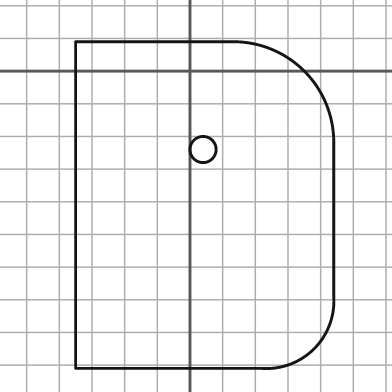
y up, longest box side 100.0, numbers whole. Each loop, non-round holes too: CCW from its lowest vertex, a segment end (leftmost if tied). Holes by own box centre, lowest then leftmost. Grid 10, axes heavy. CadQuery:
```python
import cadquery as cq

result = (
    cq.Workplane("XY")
    .moveTo(-35.0, -91.0)
    .lineTo(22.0, -91.0)
    .threePointArc((38.0, -85.0), (44.0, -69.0))
    .lineTo(44.0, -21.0)
    .threePointArc((35.0, 0.0), (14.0, 9.0))
    .lineTo(-35.0, 9.0)
    .close()
    .moveTo(4.0, -24.0)
    .circle(4.0)
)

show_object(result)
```